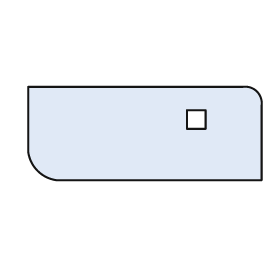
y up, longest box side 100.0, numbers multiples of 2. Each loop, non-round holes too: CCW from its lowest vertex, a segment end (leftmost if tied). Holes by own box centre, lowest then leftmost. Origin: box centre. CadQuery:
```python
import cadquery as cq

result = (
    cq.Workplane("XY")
    .moveTo(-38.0, -20.0)
    .lineTo(50.0, -20.0)
    .lineTo(50.0, 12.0)
    .threePointArc((48.0, 18.0), (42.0, 20.0))
    .lineTo(-50.0, 20.0)
    .lineTo(-50.0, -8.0)
    .threePointArc((-46.0, -16.0), (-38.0, -20.0))
    .close()
    .moveTo(18.0, 2.0)
    .lineTo(26.0, 2.0)
    .lineTo(26.0, 10.0)
    .lineTo(18.0, 10.0)
    .close()
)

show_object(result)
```